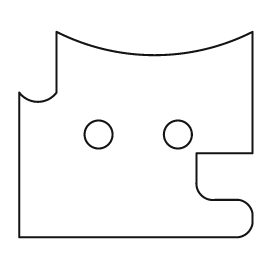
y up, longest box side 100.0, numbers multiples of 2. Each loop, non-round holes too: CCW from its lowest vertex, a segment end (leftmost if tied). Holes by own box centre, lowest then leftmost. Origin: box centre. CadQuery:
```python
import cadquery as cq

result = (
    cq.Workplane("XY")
    .moveTo(-50.0, -44.0)
    .lineTo(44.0, -44.0)
    .threePointArc((48.0, -42.0), (50.0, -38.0))
    .lineTo(50.0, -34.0)
    .threePointArc((48.0, -30.0), (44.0, -28.0))
    .lineTo(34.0, -28.0)
    .threePointArc((28.0, -26.0), (26.0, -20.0))
    .lineTo(26.0, -8.0)
    .lineTo(50.0, -8.0)
    .lineTo(50.0, 44.0)
    .threePointArc((8.0, 34.0), (-34.0, 44.0))
    .lineTo(-34.0, 18.0)
    .threePointArc((-42.0, 14.0), (-50.0, 18.0))
    .close()
    .moveTo(-16.0, 0.0)
    .circle(6.0)
    .moveTo(18.0, 0.0)
    .circle(6.0)
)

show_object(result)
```